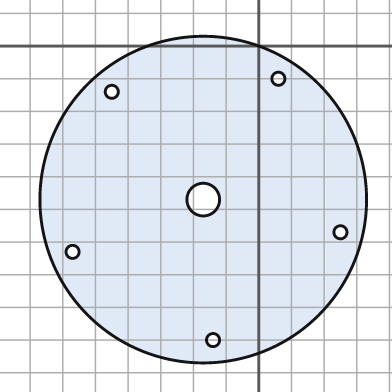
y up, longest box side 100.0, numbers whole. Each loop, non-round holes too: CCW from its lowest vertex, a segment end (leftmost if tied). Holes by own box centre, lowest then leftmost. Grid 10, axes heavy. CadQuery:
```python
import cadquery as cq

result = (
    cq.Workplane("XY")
    .moveTo(-17.0, -47.0)
    .circle(50.0)
    .moveTo(-14.0, -90.0)
    .circle(2.0)
    .moveTo(-57.0, -63.0)
    .circle(2.0)
    .moveTo(25.0, -57.0)
    .circle(2.0)
    .moveTo(-17.0, -47.0)
    .circle(5.0)
    .moveTo(-45.0, -14.0)
    .circle(2.0)
    .moveTo(6.0, -10.0)
    .circle(2.0)
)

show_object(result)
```